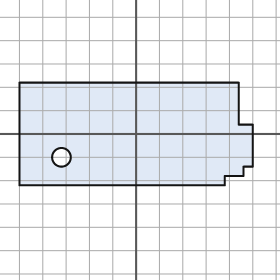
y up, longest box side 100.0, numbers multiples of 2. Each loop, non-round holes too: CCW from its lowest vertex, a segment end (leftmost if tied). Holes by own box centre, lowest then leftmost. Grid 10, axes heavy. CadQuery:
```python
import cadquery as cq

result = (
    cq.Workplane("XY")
    .moveTo(-50.0, -22.0)
    .lineTo(38.0, -22.0)
    .lineTo(38.0, -18.0)
    .lineTo(46.0, -18.0)
    .lineTo(46.0, -14.0)
    .lineTo(50.0, -14.0)
    .lineTo(50.0, 4.0)
    .lineTo(44.0, 4.0)
    .lineTo(44.0, 22.0)
    .lineTo(-50.0, 22.0)
    .close()
    .moveTo(-32.0, -10.0)
    .circle(4.0)
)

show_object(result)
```